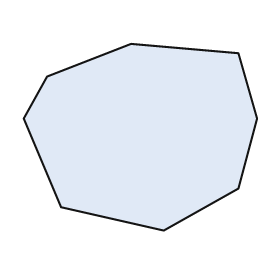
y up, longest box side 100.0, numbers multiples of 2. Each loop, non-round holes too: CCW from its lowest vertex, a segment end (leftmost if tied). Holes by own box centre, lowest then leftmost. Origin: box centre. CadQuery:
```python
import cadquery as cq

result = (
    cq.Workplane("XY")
    .moveTo(10.0, -40.0)
    .lineTo(42.0, -22.0)
    .lineTo(50.0, 8.0)
    .lineTo(42.0, 36.0)
    .lineTo(-4.0, 40.0)
    .lineTo(-40.0, 26.0)
    .lineTo(-50.0, 8.0)
    .lineTo(-34.0, -30.0)
    .close()
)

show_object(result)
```